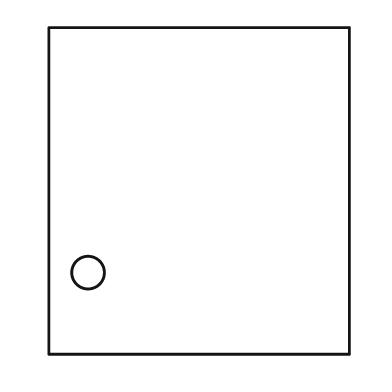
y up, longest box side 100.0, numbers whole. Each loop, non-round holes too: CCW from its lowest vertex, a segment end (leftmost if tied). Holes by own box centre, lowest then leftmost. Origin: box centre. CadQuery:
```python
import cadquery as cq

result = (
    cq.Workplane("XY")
    .moveTo(-46.0, -50.0)
    .lineTo(46.0, -50.0)
    .lineTo(46.0, 50.0)
    .lineTo(-46.0, 50.0)
    .close()
    .moveTo(-34.0, -25.0)
    .circle(5.0)
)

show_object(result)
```